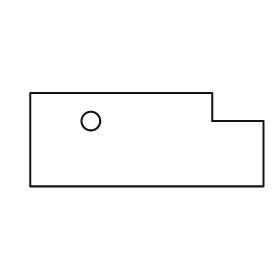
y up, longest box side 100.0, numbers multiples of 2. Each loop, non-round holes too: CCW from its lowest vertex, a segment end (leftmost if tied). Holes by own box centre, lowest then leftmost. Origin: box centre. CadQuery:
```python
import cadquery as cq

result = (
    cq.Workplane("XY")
    .moveTo(-50.0, -20.0)
    .lineTo(50.0, -20.0)
    .lineTo(50.0, 8.0)
    .lineTo(28.0, 8.0)
    .lineTo(28.0, 20.0)
    .lineTo(-50.0, 20.0)
    .close()
    .moveTo(-24.0, 8.0)
    .circle(4.0)
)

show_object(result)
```